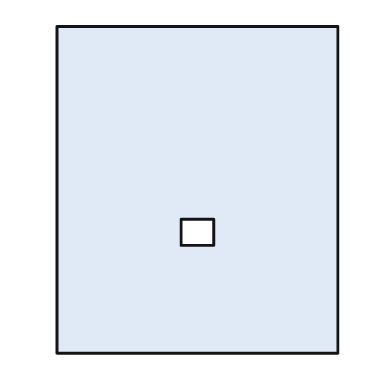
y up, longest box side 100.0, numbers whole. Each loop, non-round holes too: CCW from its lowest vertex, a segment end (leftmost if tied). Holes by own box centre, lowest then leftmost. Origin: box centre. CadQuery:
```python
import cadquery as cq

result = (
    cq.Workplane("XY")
    .moveTo(-43.0, -50.0)
    .lineTo(43.0, -50.0)
    .lineTo(43.0, 50.0)
    .lineTo(-43.0, 50.0)
    .close()
    .moveTo(-5.0, -17.0)
    .lineTo(5.0, -17.0)
    .lineTo(5.0, -9.0)
    .lineTo(-5.0, -9.0)
    .close()
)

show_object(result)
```